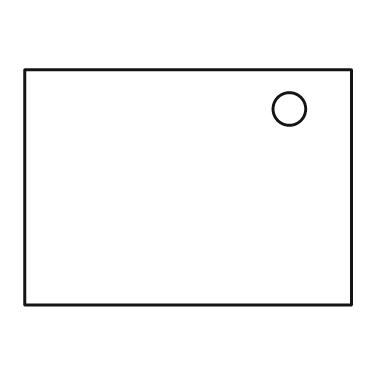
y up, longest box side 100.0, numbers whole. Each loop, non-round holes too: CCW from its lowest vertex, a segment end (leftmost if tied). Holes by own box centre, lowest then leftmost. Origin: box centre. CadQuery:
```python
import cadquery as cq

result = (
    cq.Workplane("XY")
    .moveTo(-50.0, -36.0)
    .lineTo(50.0, -36.0)
    .lineTo(50.0, 36.0)
    .lineTo(-50.0, 36.0)
    .close()
    .moveTo(31.0, 24.0)
    .circle(5.0)
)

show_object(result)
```